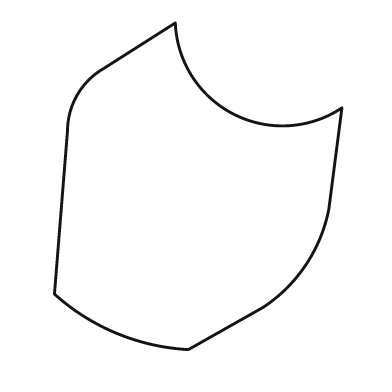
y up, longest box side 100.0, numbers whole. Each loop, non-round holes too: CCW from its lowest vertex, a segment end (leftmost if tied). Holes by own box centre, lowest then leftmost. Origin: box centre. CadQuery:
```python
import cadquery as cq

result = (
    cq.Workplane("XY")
    .moveTo(-3.0, -50.0)
    .lineTo(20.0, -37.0)
    .threePointArc((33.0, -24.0), (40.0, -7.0))
    .lineTo(44.0, 24.0)
    .threePointArc((11.0, 22.0), (-7.0, 50.0))
    .lineTo(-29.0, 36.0)
    .threePointArc((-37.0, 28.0), (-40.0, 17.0))
    .lineTo(-44.0, -33.0)
    .threePointArc((-25.0, -45.0), (-3.0, -50.0))
    .close()
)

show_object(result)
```